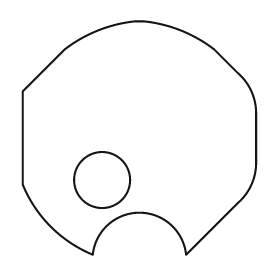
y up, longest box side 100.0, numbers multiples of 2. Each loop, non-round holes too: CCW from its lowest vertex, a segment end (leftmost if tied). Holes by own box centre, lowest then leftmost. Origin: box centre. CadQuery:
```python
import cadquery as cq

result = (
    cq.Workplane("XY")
    .moveTo(-20.0, -50.0)
    .threePointArc((0.0, -32.0), (20.0, -50.0))
    .lineTo(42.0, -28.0)
    .threePointArc((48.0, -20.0), (50.0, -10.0))
    .lineTo(50.0, 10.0)
    .threePointArc((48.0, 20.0), (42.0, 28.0))
    .lineTo(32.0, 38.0)
    .threePointArc((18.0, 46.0), (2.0, 50.0))
    .lineTo(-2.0, 50.0)
    .threePointArc((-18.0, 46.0), (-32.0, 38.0))
    .lineTo(-50.0, 20.0)
    .lineTo(-50.0, -20.0)
    .threePointArc((-38.0, -38.0), (-20.0, -50.0))
    .close()
    .moveTo(-16.0, -18.0)
    .circle(12.0)
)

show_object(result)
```